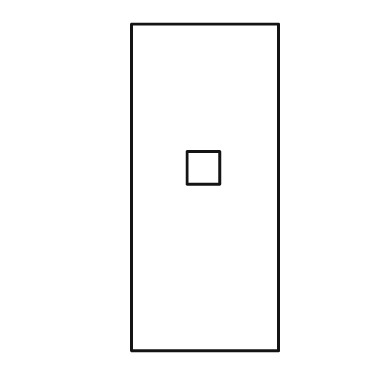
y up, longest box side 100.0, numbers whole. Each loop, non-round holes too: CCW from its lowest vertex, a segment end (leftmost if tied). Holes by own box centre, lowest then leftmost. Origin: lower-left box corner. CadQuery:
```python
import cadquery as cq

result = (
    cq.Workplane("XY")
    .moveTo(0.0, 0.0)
    .lineTo(45.0, 0.0)
    .lineTo(45.0, 100.0)
    .lineTo(0.0, 100.0)
    .close()
    .moveTo(17.0, 51.0)
    .lineTo(27.0, 51.0)
    .lineTo(27.0, 61.0)
    .lineTo(17.0, 61.0)
    .close()
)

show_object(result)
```